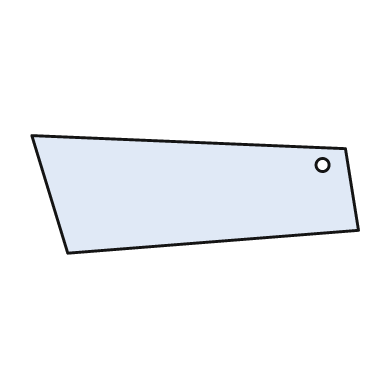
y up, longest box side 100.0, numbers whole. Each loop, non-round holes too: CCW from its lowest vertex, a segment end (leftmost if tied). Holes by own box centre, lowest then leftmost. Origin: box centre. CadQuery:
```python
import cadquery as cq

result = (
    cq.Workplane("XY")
    .moveTo(-39.0, -18.0)
    .lineTo(50.0, -11.0)
    .lineTo(46.0, 14.0)
    .lineTo(-50.0, 18.0)
    .close()
    .moveTo(39.0, 9.0)
    .circle(2.0)
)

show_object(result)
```